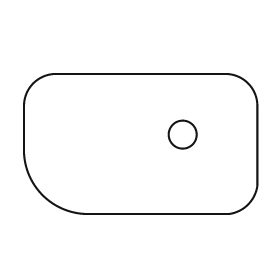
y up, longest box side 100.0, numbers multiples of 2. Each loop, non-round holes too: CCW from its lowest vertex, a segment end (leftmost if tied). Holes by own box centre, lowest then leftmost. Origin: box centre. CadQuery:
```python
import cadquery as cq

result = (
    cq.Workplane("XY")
    .moveTo(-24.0, -30.0)
    .lineTo(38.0, -30.0)
    .threePointArc((46.0, -26.0), (50.0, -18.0))
    .lineTo(50.0, 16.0)
    .threePointArc((46.0, 26.0), (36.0, 30.0))
    .lineTo(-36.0, 30.0)
    .threePointArc((-46.0, 26.0), (-50.0, 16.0))
    .lineTo(-50.0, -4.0)
    .threePointArc((-42.0, -22.0), (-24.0, -30.0))
    .close()
    .moveTo(18.0, 4.0)
    .circle(6.0)
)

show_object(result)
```